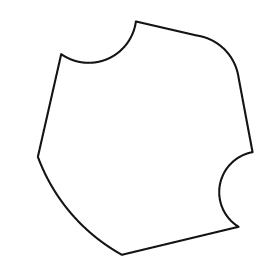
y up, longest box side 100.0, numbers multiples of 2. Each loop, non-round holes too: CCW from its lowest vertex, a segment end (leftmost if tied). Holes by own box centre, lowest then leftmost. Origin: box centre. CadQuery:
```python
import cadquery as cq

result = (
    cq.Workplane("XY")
    .moveTo(-10.0, -50.0)
    .lineTo(40.0, -38.0)
    .threePointArc((32.0, -20.0), (46.0, -6.0))
    .lineTo(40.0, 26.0)
    .threePointArc((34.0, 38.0), (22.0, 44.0))
    .lineTo(-4.0, 50.0)
    .threePointArc((-16.0, 34.0), (-36.0, 36.0))
    .lineTo(-46.0, -8.0)
    .threePointArc((-32.0, -32.0), (-10.0, -50.0))
    .close()
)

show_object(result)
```